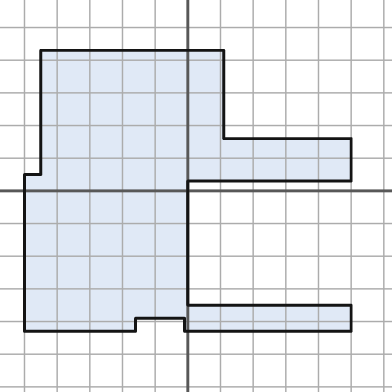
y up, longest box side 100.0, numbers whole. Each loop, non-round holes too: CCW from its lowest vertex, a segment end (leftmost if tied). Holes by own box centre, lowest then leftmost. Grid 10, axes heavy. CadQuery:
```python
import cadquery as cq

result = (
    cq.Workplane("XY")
    .moveTo(-50.0, -43.0)
    .lineTo(-16.0, -43.0)
    .lineTo(-16.0, -39.0)
    .lineTo(-1.0, -39.0)
    .lineTo(-1.0, -43.0)
    .lineTo(50.0, -43.0)
    .lineTo(50.0, -35.0)
    .lineTo(0.0, -35.0)
    .lineTo(0.0, 3.0)
    .lineTo(50.0, 3.0)
    .lineTo(50.0, 16.0)
    .lineTo(11.0, 16.0)
    .lineTo(11.0, 43.0)
    .lineTo(-45.0, 43.0)
    .lineTo(-45.0, 5.0)
    .lineTo(-50.0, 5.0)
    .close()
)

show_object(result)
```